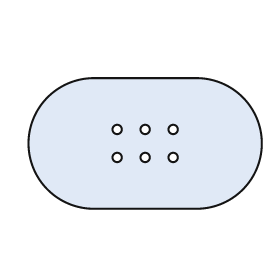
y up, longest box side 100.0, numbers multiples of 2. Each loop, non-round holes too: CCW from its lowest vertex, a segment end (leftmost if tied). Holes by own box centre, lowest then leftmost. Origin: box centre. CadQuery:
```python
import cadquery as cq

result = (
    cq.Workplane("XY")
    .moveTo(-22.0, -28.0)
    .lineTo(22.0, -28.0)
    .threePointArc((50.0, 0.0), (22.0, 28.0))
    .lineTo(-22.0, 28.0)
    .threePointArc((-50.0, 0.0), (-22.0, -28.0))
    .close()
    .moveTo(-12.0, -6.0)
    .circle(2.0)
    .moveTo(0.0, -6.0)
    .circle(2.0)
    .moveTo(12.0, -6.0)
    .circle(2.0)
    .moveTo(-12.0, 6.0)
    .circle(2.0)
    .moveTo(0.0, 6.0)
    .circle(2.0)
    .moveTo(12.0, 6.0)
    .circle(2.0)
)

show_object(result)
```